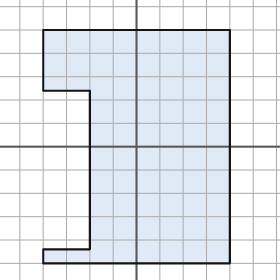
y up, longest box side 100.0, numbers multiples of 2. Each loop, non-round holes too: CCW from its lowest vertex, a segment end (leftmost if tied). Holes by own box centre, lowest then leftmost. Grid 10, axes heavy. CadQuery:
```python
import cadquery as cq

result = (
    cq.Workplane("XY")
    .moveTo(-40.0, -50.0)
    .lineTo(40.0, -50.0)
    .lineTo(40.0, 50.0)
    .lineTo(-40.0, 50.0)
    .lineTo(-40.0, 24.0)
    .lineTo(-20.0, 24.0)
    .lineTo(-20.0, -44.0)
    .lineTo(-40.0, -44.0)
    .close()
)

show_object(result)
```